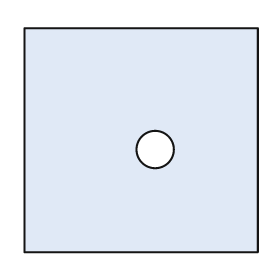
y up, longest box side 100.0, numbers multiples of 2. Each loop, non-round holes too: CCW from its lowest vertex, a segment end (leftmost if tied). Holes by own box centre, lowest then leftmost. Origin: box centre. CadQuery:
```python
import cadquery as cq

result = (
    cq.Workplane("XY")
    .moveTo(-50.0, -48.0)
    .lineTo(50.0, -48.0)
    .lineTo(50.0, 48.0)
    .lineTo(-50.0, 48.0)
    .close()
    .moveTo(6.0, -4.0)
    .circle(8.0)
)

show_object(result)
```